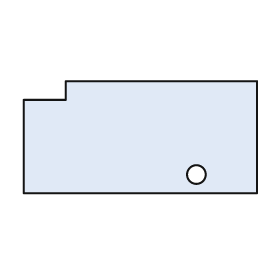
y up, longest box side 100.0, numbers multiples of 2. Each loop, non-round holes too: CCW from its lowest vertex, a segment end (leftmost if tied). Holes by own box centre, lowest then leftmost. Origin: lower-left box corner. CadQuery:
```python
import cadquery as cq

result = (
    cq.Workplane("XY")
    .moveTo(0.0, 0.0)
    .lineTo(100.0, 0.0)
    .lineTo(100.0, 48.0)
    .lineTo(18.0, 48.0)
    .lineTo(18.0, 40.0)
    .lineTo(0.0, 40.0)
    .close()
    .moveTo(74.0, 8.0)
    .circle(4.0)
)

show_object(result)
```